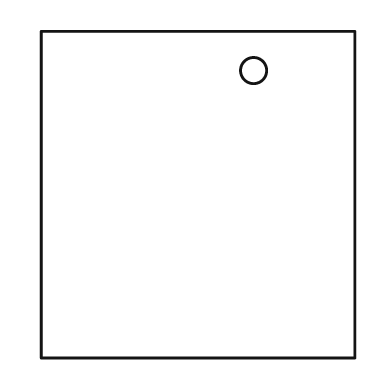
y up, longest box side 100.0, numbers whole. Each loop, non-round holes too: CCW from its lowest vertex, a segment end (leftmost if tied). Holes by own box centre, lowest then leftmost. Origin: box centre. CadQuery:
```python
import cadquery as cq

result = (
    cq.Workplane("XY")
    .moveTo(-48.0, -50.0)
    .lineTo(48.0, -50.0)
    .lineTo(48.0, 50.0)
    .lineTo(-48.0, 50.0)
    .close()
    .moveTo(17.0, 38.0)
    .circle(4.0)
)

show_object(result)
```